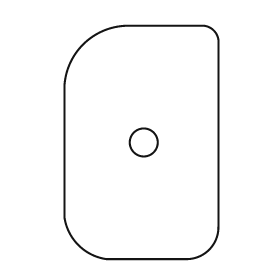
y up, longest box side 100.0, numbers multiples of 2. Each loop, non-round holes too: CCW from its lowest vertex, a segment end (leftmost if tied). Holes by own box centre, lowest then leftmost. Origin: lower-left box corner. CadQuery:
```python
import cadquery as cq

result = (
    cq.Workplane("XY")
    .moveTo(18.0, 0.0)
    .lineTo(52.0, 0.0)
    .threePointArc((62.0, 4.0), (66.0, 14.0))
    .lineTo(66.0, 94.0)
    .threePointArc((64.0, 98.0), (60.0, 100.0))
    .lineTo(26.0, 100.0)
    .threePointArc((8.0, 92.0), (0.0, 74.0))
    .lineTo(0.0, 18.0)
    .threePointArc((6.0, 6.0), (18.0, 0.0))
    .close()
    .moveTo(34.0, 50.0)
    .circle(6.0)
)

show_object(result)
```